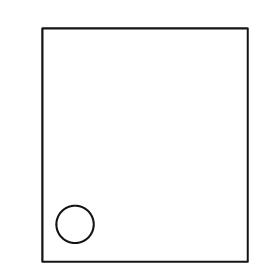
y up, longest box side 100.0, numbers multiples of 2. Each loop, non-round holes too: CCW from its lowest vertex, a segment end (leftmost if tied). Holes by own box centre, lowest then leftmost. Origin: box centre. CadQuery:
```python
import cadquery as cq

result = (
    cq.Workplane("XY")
    .moveTo(-44.0, -50.0)
    .lineTo(44.0, -50.0)
    .lineTo(44.0, 50.0)
    .lineTo(-44.0, 50.0)
    .close()
    .moveTo(-30.0, -34.0)
    .circle(8.0)
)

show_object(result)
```